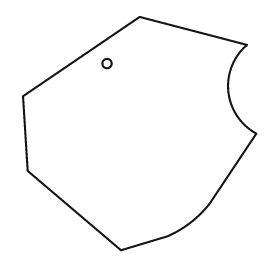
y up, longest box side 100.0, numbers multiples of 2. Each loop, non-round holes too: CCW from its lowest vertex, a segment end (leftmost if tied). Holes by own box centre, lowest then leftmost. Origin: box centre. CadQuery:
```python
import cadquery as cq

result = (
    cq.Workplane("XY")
    .moveTo(-8.0, -50.0)
    .lineTo(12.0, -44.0)
    .threePointArc((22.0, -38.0), (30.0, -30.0))
    .lineTo(50.0, 0.0)
    .threePointArc((38.0, 18.0), (46.0, 38.0))
    .lineTo(0.0, 50.0)
    .lineTo(-50.0, 16.0)
    .lineTo(-48.0, -16.0)
    .close()
    .moveTo(-14.0, 30.0)
    .circle(2.0)
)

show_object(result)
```